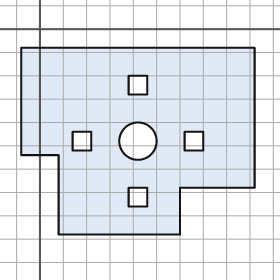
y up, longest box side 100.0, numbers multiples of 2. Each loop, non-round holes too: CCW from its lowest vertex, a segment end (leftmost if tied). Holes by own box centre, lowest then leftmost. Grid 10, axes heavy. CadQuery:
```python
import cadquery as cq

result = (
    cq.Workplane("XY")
    .moveTo(8.0, -88.0)
    .lineTo(60.0, -88.0)
    .lineTo(60.0, -68.0)
    .lineTo(92.0, -68.0)
    .lineTo(92.0, -8.0)
    .lineTo(-8.0, -8.0)
    .lineTo(-8.0, -54.0)
    .lineTo(8.0, -54.0)
    .close()
    .moveTo(38.0, -76.0)
    .lineTo(46.0, -76.0)
    .lineTo(46.0, -68.0)
    .lineTo(38.0, -68.0)
    .close()
    .moveTo(14.0, -52.0)
    .lineTo(22.0, -52.0)
    .lineTo(22.0, -44.0)
    .lineTo(14.0, -44.0)
    .close()
    .moveTo(42.0, -48.0)
    .circle(8.0)
    .moveTo(62.0, -52.0)
    .lineTo(70.0, -52.0)
    .lineTo(70.0, -44.0)
    .lineTo(62.0, -44.0)
    .close()
    .moveTo(38.0, -28.0)
    .lineTo(46.0, -28.0)
    .lineTo(46.0, -20.0)
    .lineTo(38.0, -20.0)
    .close()
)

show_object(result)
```